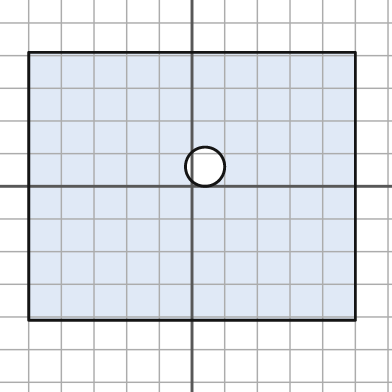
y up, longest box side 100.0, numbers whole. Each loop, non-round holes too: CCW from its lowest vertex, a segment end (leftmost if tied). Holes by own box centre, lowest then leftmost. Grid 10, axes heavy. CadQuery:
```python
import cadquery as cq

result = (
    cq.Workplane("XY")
    .moveTo(-50.0, -41.0)
    .lineTo(50.0, -41.0)
    .lineTo(50.0, 41.0)
    .lineTo(-50.0, 41.0)
    .close()
    .moveTo(4.0, 6.0)
    .circle(6.0)
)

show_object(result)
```